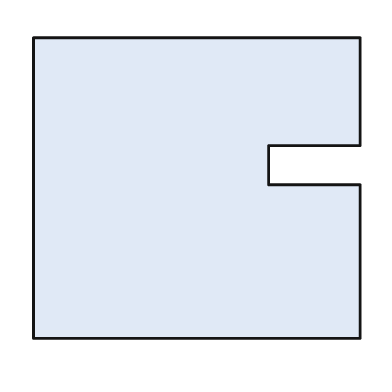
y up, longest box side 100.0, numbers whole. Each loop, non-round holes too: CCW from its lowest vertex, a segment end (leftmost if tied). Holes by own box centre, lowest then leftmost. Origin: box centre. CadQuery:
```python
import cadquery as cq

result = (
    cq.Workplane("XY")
    .moveTo(-50.0, -46.0)
    .lineTo(50.0, -46.0)
    .lineTo(50.0, 1.0)
    .lineTo(22.0, 1.0)
    .lineTo(22.0, 13.0)
    .lineTo(50.0, 13.0)
    .lineTo(50.0, 46.0)
    .lineTo(-50.0, 46.0)
    .close()
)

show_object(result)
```